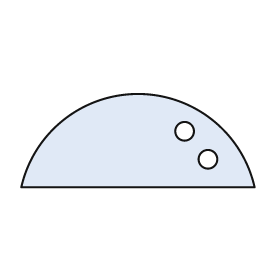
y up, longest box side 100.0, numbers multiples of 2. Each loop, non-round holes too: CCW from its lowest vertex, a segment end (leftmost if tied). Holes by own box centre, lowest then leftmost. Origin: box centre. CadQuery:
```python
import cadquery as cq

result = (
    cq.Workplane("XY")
    .moveTo(-50.0, -20.0)
    .lineTo(50.0, -20.0)
    .threePointArc((0.0, 20.0), (-50.0, -20.0))
    .close()
    .moveTo(30.0, -8.0)
    .circle(4.0)
    .moveTo(20.0, 4.0)
    .circle(4.0)
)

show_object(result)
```